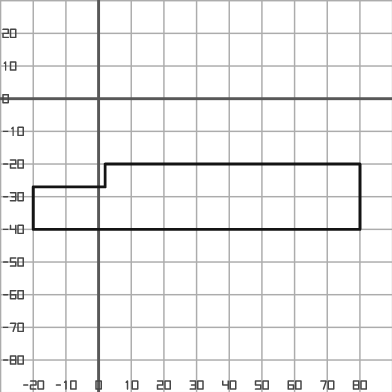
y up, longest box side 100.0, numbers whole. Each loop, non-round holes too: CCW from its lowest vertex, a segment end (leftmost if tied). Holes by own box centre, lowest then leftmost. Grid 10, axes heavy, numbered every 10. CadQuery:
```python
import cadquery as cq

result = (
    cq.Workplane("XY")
    .moveTo(-20.0, -40.0)
    .lineTo(80.0, -40.0)
    .lineTo(80.0, -20.0)
    .lineTo(2.0, -20.0)
    .lineTo(2.0, -27.0)
    .lineTo(-20.0, -27.0)
    .close()
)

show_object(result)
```